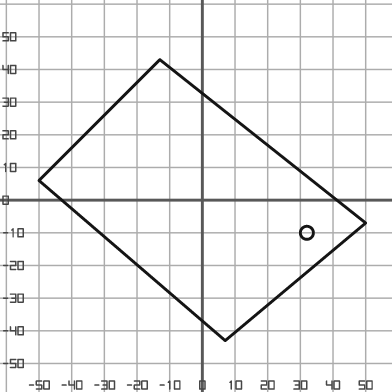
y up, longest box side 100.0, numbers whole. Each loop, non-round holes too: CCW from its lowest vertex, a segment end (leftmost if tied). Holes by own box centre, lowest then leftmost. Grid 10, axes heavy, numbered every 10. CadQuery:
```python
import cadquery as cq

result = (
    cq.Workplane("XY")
    .moveTo(7.0, -43.0)
    .lineTo(50.0, -7.0)
    .lineTo(-13.0, 43.0)
    .lineTo(-50.0, 6.0)
    .close()
    .moveTo(32.0, -10.0)
    .circle(2.0)
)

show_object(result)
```